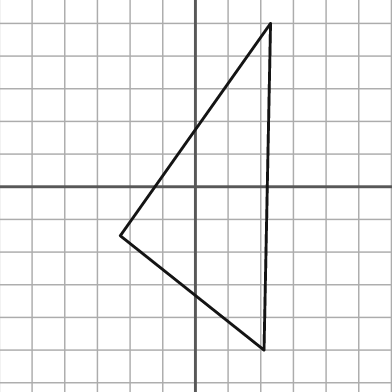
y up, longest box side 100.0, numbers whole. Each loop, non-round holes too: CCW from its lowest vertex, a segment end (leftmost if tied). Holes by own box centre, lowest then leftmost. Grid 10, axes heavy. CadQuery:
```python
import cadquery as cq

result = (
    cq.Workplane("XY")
    .moveTo(21.0, -50.0)
    .lineTo(23.0, 50.0)
    .lineTo(-23.0, -15.0)
    .close()
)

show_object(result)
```